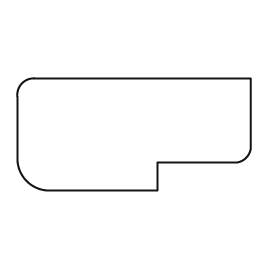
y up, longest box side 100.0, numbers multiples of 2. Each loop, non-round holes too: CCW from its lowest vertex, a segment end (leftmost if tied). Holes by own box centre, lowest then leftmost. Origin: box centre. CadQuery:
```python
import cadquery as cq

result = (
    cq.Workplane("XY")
    .moveTo(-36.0, -24.0)
    .lineTo(10.0, -24.0)
    .lineTo(10.0, -12.0)
    .lineTo(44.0, -12.0)
    .threePointArc((48.0, -10.0), (50.0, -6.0))
    .lineTo(50.0, 24.0)
    .lineTo(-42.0, 24.0)
    .threePointArc((-48.0, 22.0), (-50.0, 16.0))
    .lineTo(-50.0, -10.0)
    .threePointArc((-46.0, -20.0), (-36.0, -24.0))
    .close()
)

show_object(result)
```